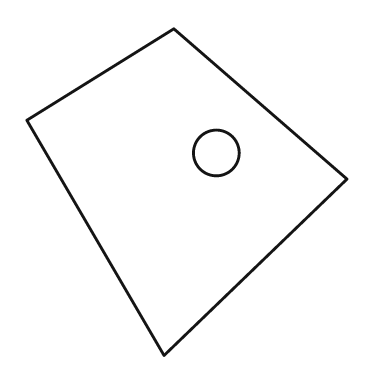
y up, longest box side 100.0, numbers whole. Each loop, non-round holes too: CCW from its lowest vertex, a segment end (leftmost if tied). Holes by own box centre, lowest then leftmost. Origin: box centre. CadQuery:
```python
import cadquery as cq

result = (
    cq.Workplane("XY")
    .moveTo(-7.0, -50.0)
    .lineTo(49.0, 4.0)
    .lineTo(-4.0, 50.0)
    .lineTo(-49.0, 22.0)
    .close()
    .moveTo(9.0, 12.0)
    .circle(7.0)
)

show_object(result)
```